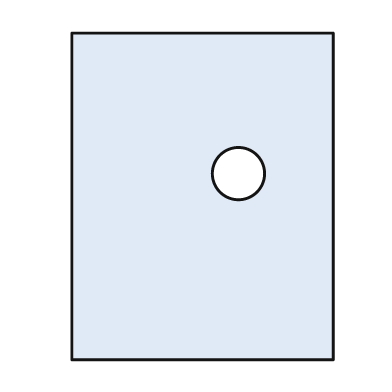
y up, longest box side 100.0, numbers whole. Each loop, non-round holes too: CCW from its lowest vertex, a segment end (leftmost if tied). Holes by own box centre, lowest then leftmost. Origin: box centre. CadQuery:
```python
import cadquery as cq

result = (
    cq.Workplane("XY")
    .moveTo(-40.0, -50.0)
    .lineTo(40.0, -50.0)
    .lineTo(40.0, 50.0)
    .lineTo(-40.0, 50.0)
    .close()
    .moveTo(11.0, 7.0)
    .circle(8.0)
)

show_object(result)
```